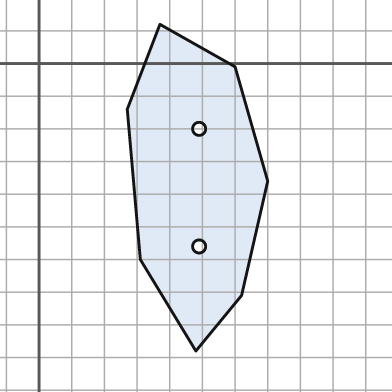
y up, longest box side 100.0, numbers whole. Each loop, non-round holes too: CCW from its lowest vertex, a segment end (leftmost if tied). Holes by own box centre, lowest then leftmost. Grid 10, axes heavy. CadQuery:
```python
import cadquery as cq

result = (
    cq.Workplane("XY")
    .moveTo(48.0, -88.0)
    .lineTo(62.0, -71.0)
    .lineTo(70.0, -36.0)
    .lineTo(60.0, -1.0)
    .lineTo(37.0, 12.0)
    .lineTo(27.0, -14.0)
    .lineTo(31.0, -60.0)
    .close()
    .moveTo(49.0, -56.0)
    .circle(2.0)
    .moveTo(49.0, -20.0)
    .circle(2.0)
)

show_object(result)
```